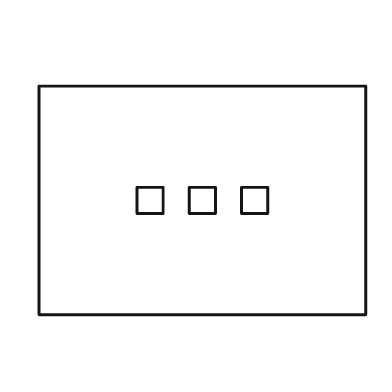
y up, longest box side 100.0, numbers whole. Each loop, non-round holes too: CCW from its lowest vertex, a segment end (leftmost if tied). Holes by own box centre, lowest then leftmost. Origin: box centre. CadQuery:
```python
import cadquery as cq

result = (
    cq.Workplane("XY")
    .moveTo(-50.0, -35.0)
    .lineTo(50.0, -35.0)
    .lineTo(50.0, 35.0)
    .lineTo(-50.0, 35.0)
    .close()
    .moveTo(-20.0, -4.0)
    .lineTo(-12.0, -4.0)
    .lineTo(-12.0, 4.0)
    .lineTo(-20.0, 4.0)
    .close()
    .moveTo(-4.0, -4.0)
    .lineTo(4.0, -4.0)
    .lineTo(4.0, 4.0)
    .lineTo(-4.0, 4.0)
    .close()
    .moveTo(12.0, -4.0)
    .lineTo(20.0, -4.0)
    .lineTo(20.0, 4.0)
    .lineTo(12.0, 4.0)
    .close()
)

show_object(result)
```